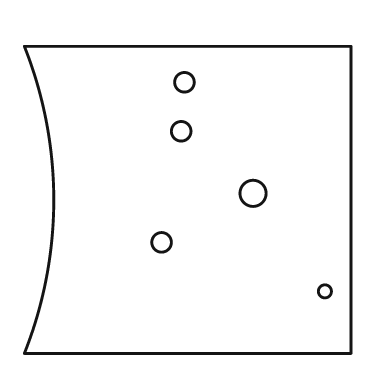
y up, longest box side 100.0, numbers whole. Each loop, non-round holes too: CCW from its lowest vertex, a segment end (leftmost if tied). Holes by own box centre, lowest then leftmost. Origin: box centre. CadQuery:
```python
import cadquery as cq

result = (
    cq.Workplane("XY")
    .moveTo(-50.0, -47.0)
    .lineTo(50.0, -47.0)
    .lineTo(50.0, 47.0)
    .lineTo(-50.0, 47.0)
    .threePointArc((-41.0, 0.0), (-50.0, -47.0))
    .close()
    .moveTo(42.0, -28.0)
    .circle(2.0)
    .moveTo(-8.0, -13.0)
    .circle(3.0)
    .moveTo(20.0, 2.0)
    .circle(4.0)
    .moveTo(-2.0, 21.0)
    .circle(3.0)
    .moveTo(-1.0, 36.0)
    .circle(3.0)
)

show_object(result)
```